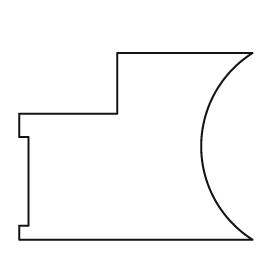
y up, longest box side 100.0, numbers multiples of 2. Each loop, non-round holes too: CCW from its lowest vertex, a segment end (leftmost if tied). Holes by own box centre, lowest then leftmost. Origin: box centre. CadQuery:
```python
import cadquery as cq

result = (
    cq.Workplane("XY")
    .moveTo(-50.0, -40.0)
    .lineTo(50.0, -40.0)
    .threePointArc((28.0, 0.0), (50.0, 40.0))
    .lineTo(-8.0, 40.0)
    .lineTo(-8.0, 14.0)
    .lineTo(-50.0, 14.0)
    .lineTo(-50.0, 4.0)
    .lineTo(-46.0, 4.0)
    .lineTo(-46.0, -34.0)
    .lineTo(-50.0, -34.0)
    .close()
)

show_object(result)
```